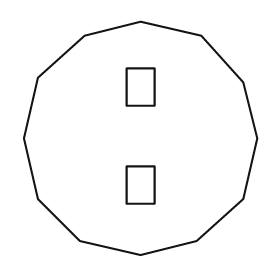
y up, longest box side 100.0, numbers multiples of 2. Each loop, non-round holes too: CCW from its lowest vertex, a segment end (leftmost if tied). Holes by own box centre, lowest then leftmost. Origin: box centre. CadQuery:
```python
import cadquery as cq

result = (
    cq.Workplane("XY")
    .moveTo(0.0, -50.0)
    .lineTo(24.0, -44.0)
    .lineTo(44.0, -26.0)
    .lineTo(50.0, 0.0)
    .lineTo(44.0, 24.0)
    .lineTo(26.0, 44.0)
    .lineTo(0.0, 50.0)
    .lineTo(-24.0, 44.0)
    .lineTo(-44.0, 26.0)
    .lineTo(-50.0, 0.0)
    .lineTo(-44.0, -26.0)
    .lineTo(-26.0, -44.0)
    .close()
    .moveTo(-6.0, -28.0)
    .lineTo(6.0, -28.0)
    .lineTo(6.0, -12.0)
    .lineTo(-6.0, -12.0)
    .close()
    .moveTo(-6.0, 14.0)
    .lineTo(6.0, 14.0)
    .lineTo(6.0, 30.0)
    .lineTo(-6.0, 30.0)
    .close()
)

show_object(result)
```